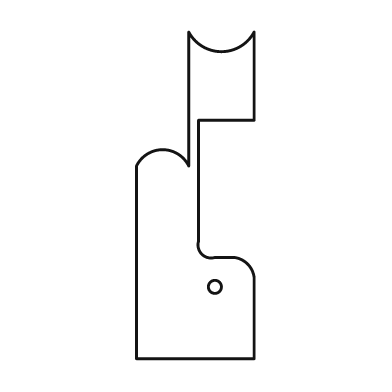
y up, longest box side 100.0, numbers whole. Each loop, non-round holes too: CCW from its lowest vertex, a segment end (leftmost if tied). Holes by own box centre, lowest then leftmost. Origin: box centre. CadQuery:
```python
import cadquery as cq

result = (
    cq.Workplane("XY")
    .moveTo(-18.0, -50.0)
    .lineTo(18.0, -50.0)
    .lineTo(18.0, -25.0)
    .threePointArc((16.0, -21.0), (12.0, -19.0))
    .lineTo(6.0, -19.0)
    .threePointArc((2.0, -18.0), (1.0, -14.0))
    .lineTo(1.0, 23.0)
    .lineTo(18.0, 23.0)
    .lineTo(18.0, 50.0)
    .threePointArc((8.0, 44.0), (-2.0, 50.0))
    .lineTo(-2.0, 9.0)
    .threePointArc((-10.0, 14.0), (-18.0, 9.0))
    .close()
    .moveTo(6.0, -28.0)
    .circle(2.0)
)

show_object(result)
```